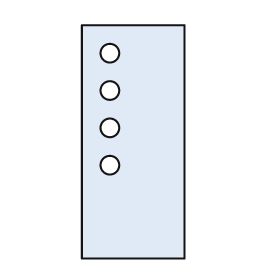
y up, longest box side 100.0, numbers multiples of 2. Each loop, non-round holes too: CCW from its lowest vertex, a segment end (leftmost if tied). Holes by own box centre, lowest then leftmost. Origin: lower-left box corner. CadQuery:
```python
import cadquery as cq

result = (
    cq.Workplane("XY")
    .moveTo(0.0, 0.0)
    .lineTo(44.0, 0.0)
    .lineTo(44.0, 100.0)
    .lineTo(0.0, 100.0)
    .close()
    .moveTo(12.0, 40.0)
    .circle(4.0)
    .moveTo(12.0, 56.0)
    .circle(4.0)
    .moveTo(12.0, 72.0)
    .circle(4.0)
    .moveTo(12.0, 88.0)
    .circle(4.0)
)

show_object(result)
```